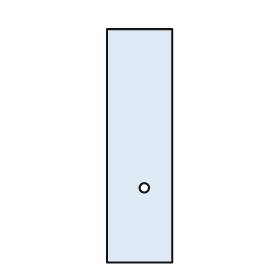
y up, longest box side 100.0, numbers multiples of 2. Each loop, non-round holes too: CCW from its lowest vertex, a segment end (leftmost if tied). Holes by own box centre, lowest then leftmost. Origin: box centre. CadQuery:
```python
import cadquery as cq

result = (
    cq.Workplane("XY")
    .moveTo(-14.0, -50.0)
    .lineTo(14.0, -50.0)
    .lineTo(14.0, 50.0)
    .lineTo(-14.0, 50.0)
    .close()
    .moveTo(2.0, -18.0)
    .circle(2.0)
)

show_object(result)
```